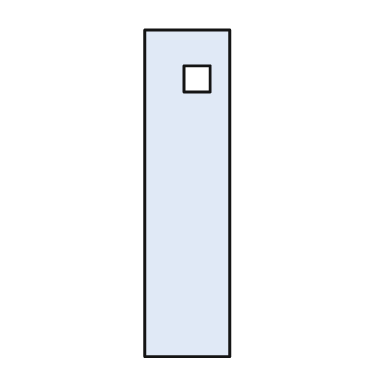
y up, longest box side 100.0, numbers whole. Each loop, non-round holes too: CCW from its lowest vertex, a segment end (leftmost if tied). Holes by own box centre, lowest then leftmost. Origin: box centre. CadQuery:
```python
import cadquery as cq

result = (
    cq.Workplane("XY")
    .moveTo(-13.0, -50.0)
    .lineTo(13.0, -50.0)
    .lineTo(13.0, 50.0)
    .lineTo(-13.0, 50.0)
    .close()
    .moveTo(-1.0, 31.0)
    .lineTo(7.0, 31.0)
    .lineTo(7.0, 39.0)
    .lineTo(-1.0, 39.0)
    .close()
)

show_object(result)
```